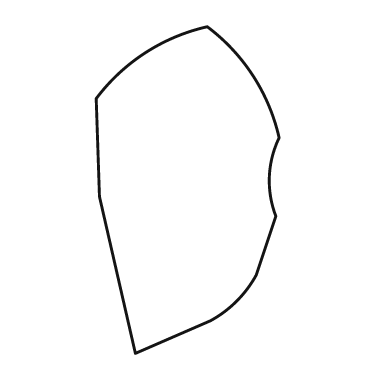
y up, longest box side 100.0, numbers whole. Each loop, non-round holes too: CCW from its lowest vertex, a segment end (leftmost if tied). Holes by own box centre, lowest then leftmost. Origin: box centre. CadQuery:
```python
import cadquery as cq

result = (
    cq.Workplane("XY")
    .moveTo(-16.0, -50.0)
    .lineTo(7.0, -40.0)
    .threePointArc((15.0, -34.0), (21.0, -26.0))
    .lineTo(27.0, -8.0)
    .threePointArc((25.0, 4.0), (28.0, 16.0))
    .threePointArc((20.0, 35.0), (6.0, 50.0))
    .threePointArc((-13.0, 42.0), (-28.0, 28.0))
    .lineTo(-27.0, -2.0)
    .close()
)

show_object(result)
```